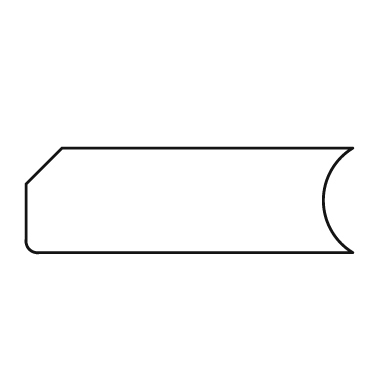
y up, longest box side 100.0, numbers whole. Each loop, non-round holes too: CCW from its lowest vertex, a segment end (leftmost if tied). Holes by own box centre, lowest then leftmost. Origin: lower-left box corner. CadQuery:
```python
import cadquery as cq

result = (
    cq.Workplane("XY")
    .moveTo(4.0, 0.0)
    .lineTo(100.0, 0.0)
    .threePointArc((91.0, 16.0), (100.0, 32.0))
    .lineTo(11.0, 32.0)
    .lineTo(0.0, 21.0)
    .lineTo(0.0, 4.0)
    .threePointArc((1.0, 1.0), (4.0, 0.0))
    .close()
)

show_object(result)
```